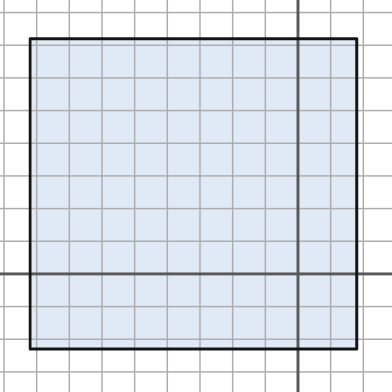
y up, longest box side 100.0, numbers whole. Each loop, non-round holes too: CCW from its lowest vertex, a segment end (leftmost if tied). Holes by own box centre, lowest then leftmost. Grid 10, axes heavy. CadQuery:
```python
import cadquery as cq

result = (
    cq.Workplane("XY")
    .moveTo(-82.0, -23.0)
    .lineTo(18.0, -23.0)
    .lineTo(18.0, 72.0)
    .lineTo(-82.0, 72.0)
    .close()
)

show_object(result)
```